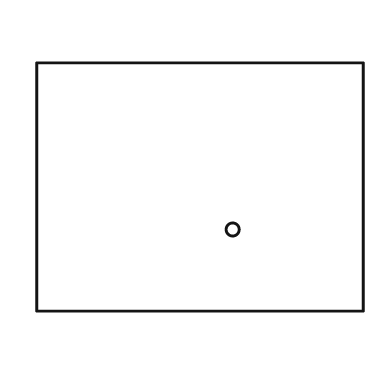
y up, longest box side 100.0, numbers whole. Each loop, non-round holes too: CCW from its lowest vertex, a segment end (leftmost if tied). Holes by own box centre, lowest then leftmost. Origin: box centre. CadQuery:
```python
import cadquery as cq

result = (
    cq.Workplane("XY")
    .moveTo(-50.0, -38.0)
    .lineTo(50.0, -38.0)
    .lineTo(50.0, 38.0)
    .lineTo(-50.0, 38.0)
    .close()
    .moveTo(10.0, -13.0)
    .circle(2.0)
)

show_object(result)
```